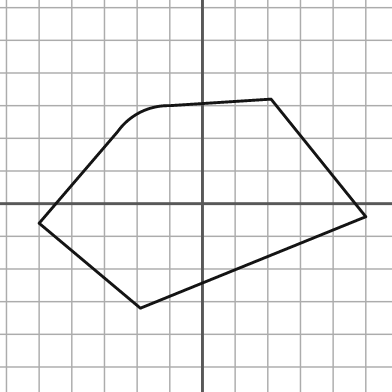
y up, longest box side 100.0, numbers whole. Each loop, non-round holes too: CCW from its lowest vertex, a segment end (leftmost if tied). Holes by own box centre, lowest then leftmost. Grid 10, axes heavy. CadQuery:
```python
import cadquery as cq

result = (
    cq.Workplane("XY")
    .moveTo(-19.0, -32.0)
    .lineTo(50.0, -4.0)
    .lineTo(21.0, 32.0)
    .lineTo(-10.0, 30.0)
    .threePointArc((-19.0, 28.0), (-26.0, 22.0))
    .lineTo(-50.0, -6.0)
    .close()
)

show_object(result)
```